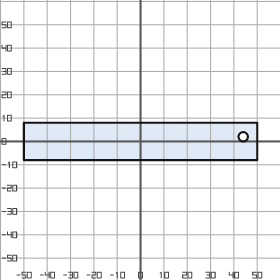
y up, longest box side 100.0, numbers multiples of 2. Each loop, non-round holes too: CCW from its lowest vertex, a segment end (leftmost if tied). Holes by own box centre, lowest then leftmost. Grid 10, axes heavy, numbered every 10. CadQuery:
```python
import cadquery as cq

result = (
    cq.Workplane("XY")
    .moveTo(-50.0, -8.0)
    .lineTo(50.0, -8.0)
    .lineTo(50.0, 8.0)
    .lineTo(-50.0, 8.0)
    .close()
    .moveTo(44.0, 2.0)
    .circle(2.0)
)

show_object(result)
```